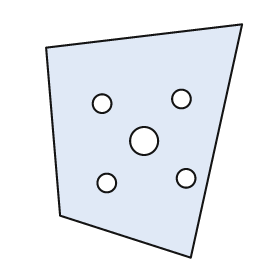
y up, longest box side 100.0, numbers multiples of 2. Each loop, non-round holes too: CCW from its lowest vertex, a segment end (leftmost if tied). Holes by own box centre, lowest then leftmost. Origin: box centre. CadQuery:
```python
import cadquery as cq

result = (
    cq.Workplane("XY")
    .moveTo(20.0, -50.0)
    .lineTo(42.0, 50.0)
    .lineTo(-42.0, 40.0)
    .lineTo(-36.0, -32.0)
    .close()
    .moveTo(-16.0, -18.0)
    .circle(4.0)
    .moveTo(18.0, -16.0)
    .circle(4.0)
    .moveTo(0.0, 0.0)
    .circle(6.0)
    .moveTo(-18.0, 16.0)
    .circle(4.0)
    .moveTo(16.0, 18.0)
    .circle(4.0)
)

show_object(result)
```